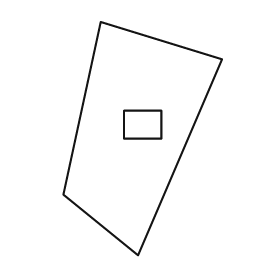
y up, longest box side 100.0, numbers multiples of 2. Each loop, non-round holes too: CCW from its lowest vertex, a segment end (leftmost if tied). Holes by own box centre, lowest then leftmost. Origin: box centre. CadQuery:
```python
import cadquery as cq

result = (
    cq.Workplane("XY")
    .moveTo(-2.0, -50.0)
    .lineTo(34.0, 34.0)
    .lineTo(-18.0, 50.0)
    .lineTo(-34.0, -24.0)
    .close()
    .moveTo(-8.0, 0.0)
    .lineTo(8.0, 0.0)
    .lineTo(8.0, 12.0)
    .lineTo(-8.0, 12.0)
    .close()
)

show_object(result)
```